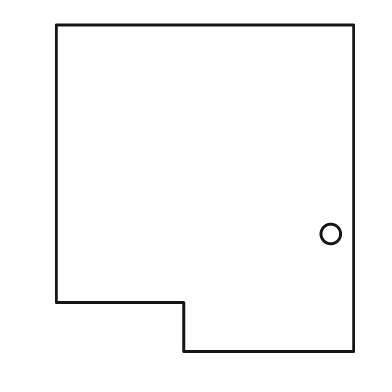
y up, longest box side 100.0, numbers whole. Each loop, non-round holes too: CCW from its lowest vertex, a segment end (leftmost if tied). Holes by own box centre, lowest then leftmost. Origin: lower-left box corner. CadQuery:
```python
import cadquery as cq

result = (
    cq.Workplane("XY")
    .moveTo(39.0, 0.0)
    .lineTo(91.0, 0.0)
    .lineTo(91.0, 100.0)
    .lineTo(0.0, 100.0)
    .lineTo(0.0, 15.0)
    .lineTo(39.0, 15.0)
    .close()
    .moveTo(84.0, 36.0)
    .circle(3.0)
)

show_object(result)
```